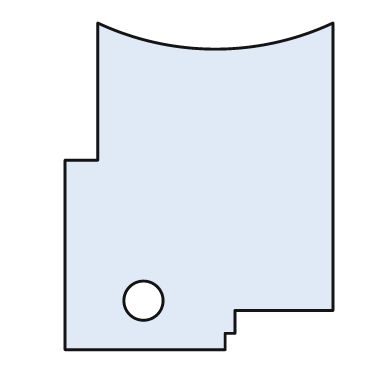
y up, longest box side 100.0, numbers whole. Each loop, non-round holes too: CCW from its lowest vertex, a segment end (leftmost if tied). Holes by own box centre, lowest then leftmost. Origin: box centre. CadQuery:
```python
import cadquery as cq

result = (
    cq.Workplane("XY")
    .moveTo(-41.0, -50.0)
    .lineTo(8.0, -50.0)
    .lineTo(8.0, -45.0)
    .lineTo(11.0, -45.0)
    .lineTo(11.0, -38.0)
    .lineTo(41.0, -38.0)
    .lineTo(41.0, 50.0)
    .threePointArc((5.0, 42.0), (-31.0, 50.0))
    .lineTo(-31.0, 8.0)
    .lineTo(-41.0, 8.0)
    .close()
    .moveTo(-17.0, -35.0)
    .circle(6.0)
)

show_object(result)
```